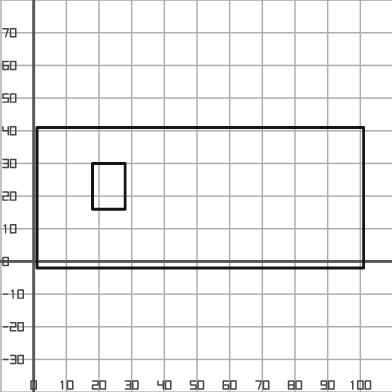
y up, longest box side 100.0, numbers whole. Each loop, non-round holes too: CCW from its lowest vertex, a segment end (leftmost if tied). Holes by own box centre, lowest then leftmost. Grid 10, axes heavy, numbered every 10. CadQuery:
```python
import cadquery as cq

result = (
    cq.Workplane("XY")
    .moveTo(1.0, -2.0)
    .lineTo(101.0, -2.0)
    .lineTo(101.0, 41.0)
    .lineTo(1.0, 41.0)
    .close()
    .moveTo(18.0, 16.0)
    .lineTo(28.0, 16.0)
    .lineTo(28.0, 30.0)
    .lineTo(18.0, 30.0)
    .close()
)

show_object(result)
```